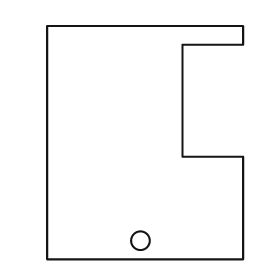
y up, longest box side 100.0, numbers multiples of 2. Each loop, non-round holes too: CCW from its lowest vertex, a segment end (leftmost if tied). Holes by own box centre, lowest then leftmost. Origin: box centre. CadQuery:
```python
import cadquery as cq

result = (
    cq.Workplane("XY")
    .moveTo(-42.0, -50.0)
    .lineTo(42.0, -50.0)
    .lineTo(42.0, -6.0)
    .lineTo(16.0, -6.0)
    .lineTo(16.0, 42.0)
    .lineTo(42.0, 42.0)
    .lineTo(42.0, 50.0)
    .lineTo(-42.0, 50.0)
    .close()
    .moveTo(-2.0, -42.0)
    .circle(4.0)
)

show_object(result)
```